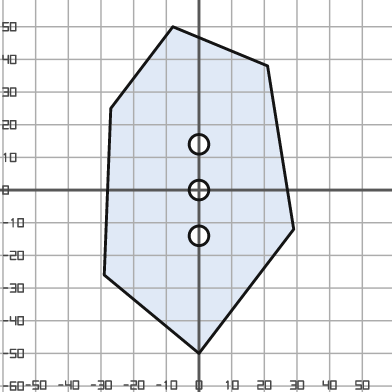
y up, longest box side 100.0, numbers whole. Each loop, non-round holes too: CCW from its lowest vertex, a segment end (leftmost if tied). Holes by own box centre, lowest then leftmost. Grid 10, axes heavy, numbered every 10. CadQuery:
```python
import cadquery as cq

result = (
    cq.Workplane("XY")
    .moveTo(0.0, -50.0)
    .lineTo(29.0, -12.0)
    .lineTo(21.0, 38.0)
    .lineTo(-8.0, 50.0)
    .lineTo(-27.0, 25.0)
    .lineTo(-29.0, -26.0)
    .close()
    .moveTo(0.0, -14.0)
    .circle(3.0)
    .moveTo(0.0, 0.0)
    .circle(3.0)
    .moveTo(0.0, 14.0)
    .circle(3.0)
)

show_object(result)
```